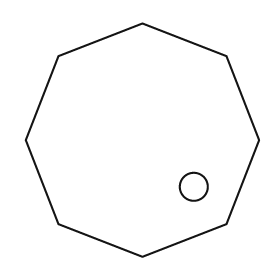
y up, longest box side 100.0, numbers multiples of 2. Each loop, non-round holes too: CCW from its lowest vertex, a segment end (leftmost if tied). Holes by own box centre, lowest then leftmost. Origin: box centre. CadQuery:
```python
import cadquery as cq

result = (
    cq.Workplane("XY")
    .moveTo(0.0, -50.0)
    .lineTo(36.0, -36.0)
    .lineTo(50.0, 0.0)
    .lineTo(36.0, 36.0)
    .lineTo(0.0, 50.0)
    .lineTo(-36.0, 36.0)
    .lineTo(-50.0, 0.0)
    .lineTo(-36.0, -36.0)
    .close()
    .moveTo(22.0, -20.0)
    .circle(6.0)
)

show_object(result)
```